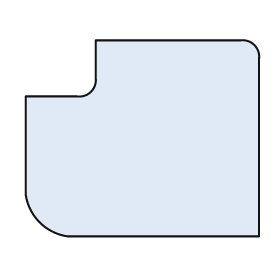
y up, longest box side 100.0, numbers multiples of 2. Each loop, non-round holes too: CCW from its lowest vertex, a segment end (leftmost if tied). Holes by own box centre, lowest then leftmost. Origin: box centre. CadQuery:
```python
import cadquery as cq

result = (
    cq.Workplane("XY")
    .moveTo(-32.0, -42.0)
    .lineTo(50.0, -42.0)
    .lineTo(50.0, 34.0)
    .threePointArc((48.0, 40.0), (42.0, 42.0))
    .lineTo(-20.0, 42.0)
    .lineTo(-20.0, 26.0)
    .threePointArc((-22.0, 20.0), (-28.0, 18.0))
    .lineTo(-50.0, 18.0)
    .lineTo(-50.0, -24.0)
    .threePointArc((-44.0, -36.0), (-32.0, -42.0))
    .close()
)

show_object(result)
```